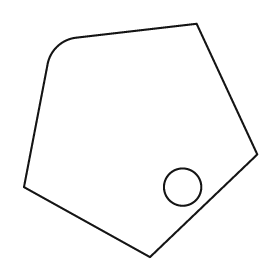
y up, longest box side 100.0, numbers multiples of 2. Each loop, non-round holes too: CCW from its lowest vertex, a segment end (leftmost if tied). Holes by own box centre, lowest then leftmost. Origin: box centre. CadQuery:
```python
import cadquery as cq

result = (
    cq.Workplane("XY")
    .moveTo(4.0, -50.0)
    .lineTo(50.0, -6.0)
    .lineTo(24.0, 50.0)
    .lineTo(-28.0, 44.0)
    .threePointArc((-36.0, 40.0), (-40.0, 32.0))
    .lineTo(-50.0, -20.0)
    .close()
    .moveTo(18.0, -20.0)
    .circle(8.0)
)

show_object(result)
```